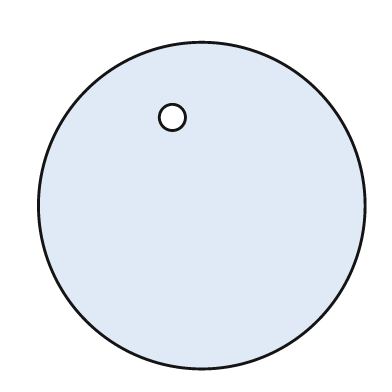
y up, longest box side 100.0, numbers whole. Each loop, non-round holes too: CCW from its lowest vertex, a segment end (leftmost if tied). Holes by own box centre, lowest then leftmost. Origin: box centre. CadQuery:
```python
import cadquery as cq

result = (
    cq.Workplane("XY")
    .moveTo(0.0, 0.0)
    .circle(50.0)
    .moveTo(-9.0, 27.0)
    .circle(4.0)
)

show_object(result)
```